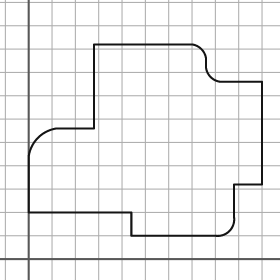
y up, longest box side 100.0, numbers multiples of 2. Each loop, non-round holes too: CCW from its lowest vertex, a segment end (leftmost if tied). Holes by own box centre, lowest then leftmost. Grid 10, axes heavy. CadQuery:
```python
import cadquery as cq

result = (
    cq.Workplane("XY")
    .moveTo(44.0, 10.0)
    .lineTo(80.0, 10.0)
    .threePointArc((86.0, 12.0), (88.0, 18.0))
    .lineTo(88.0, 32.0)
    .lineTo(100.0, 32.0)
    .lineTo(100.0, 76.0)
    .lineTo(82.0, 76.0)
    .threePointArc((78.0, 78.0), (76.0, 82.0))
    .lineTo(76.0, 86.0)
    .threePointArc((74.0, 90.0), (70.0, 92.0))
    .lineTo(28.0, 92.0)
    .lineTo(28.0, 56.0)
    .lineTo(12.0, 56.0)
    .threePointArc((4.0, 52.0), (0.0, 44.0))
    .lineTo(0.0, 20.0)
    .lineTo(44.0, 20.0)
    .close()
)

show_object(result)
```